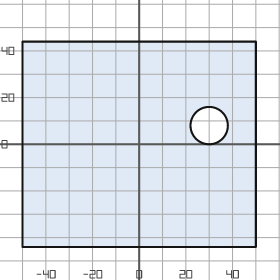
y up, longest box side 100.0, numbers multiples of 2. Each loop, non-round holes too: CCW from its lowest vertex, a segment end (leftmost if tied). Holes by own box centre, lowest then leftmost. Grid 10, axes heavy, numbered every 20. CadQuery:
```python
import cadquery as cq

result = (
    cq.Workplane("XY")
    .moveTo(-50.0, -44.0)
    .lineTo(50.0, -44.0)
    .lineTo(50.0, 44.0)
    .lineTo(-50.0, 44.0)
    .close()
    .moveTo(30.0, 8.0)
    .circle(8.0)
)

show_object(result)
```